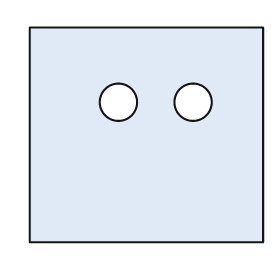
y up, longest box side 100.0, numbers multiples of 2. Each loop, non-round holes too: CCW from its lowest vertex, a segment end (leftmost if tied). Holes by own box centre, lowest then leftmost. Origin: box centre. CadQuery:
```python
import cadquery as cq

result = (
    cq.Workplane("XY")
    .moveTo(-50.0, -46.0)
    .lineTo(50.0, -46.0)
    .lineTo(50.0, 46.0)
    .lineTo(-50.0, 46.0)
    .close()
    .moveTo(-12.0, 14.0)
    .circle(8.0)
    .moveTo(20.0, 14.0)
    .circle(8.0)
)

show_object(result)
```